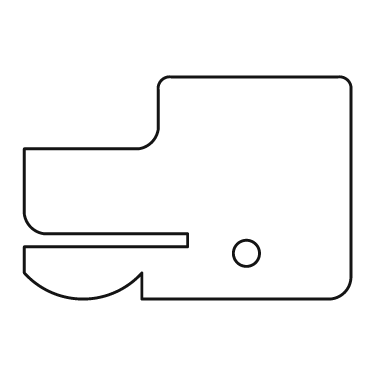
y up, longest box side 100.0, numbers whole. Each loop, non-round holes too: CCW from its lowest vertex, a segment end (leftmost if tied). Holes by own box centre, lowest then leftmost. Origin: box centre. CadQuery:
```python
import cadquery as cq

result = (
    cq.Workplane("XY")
    .moveTo(-14.0, -34.0)
    .lineTo(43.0, -34.0)
    .threePointArc((48.0, -32.0), (50.0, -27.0))
    .lineTo(50.0, 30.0)
    .threePointArc((49.0, 33.0), (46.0, 34.0))
    .lineTo(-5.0, 34.0)
    .threePointArc((-8.0, 33.0), (-9.0, 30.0))
    .lineTo(-9.0, 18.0)
    .threePointArc((-11.0, 14.0), (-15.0, 12.0))
    .lineTo(-50.0, 12.0)
    .lineTo(-50.0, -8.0)
    .threePointArc((-48.0, -12.0), (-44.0, -14.0))
    .lineTo(0.0, -14.0)
    .lineTo(0.0, -18.0)
    .lineTo(-50.0, -18.0)
    .lineTo(-50.0, -26.0)
    .threePointArc((-32.0, -34.0), (-14.0, -26.0))
    .close()
    .moveTo(18.0, -20.0)
    .circle(4.0)
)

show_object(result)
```